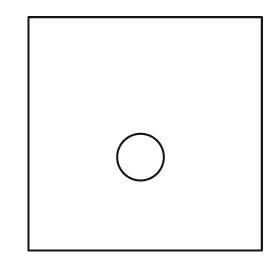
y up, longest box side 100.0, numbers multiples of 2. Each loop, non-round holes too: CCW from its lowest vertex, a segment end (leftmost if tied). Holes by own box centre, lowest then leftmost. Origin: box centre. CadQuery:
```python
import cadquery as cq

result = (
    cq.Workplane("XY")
    .moveTo(-50.0, -50.0)
    .lineTo(50.0, -50.0)
    .lineTo(50.0, 50.0)
    .lineTo(-50.0, 50.0)
    .close()
    .moveTo(-2.0, -10.0)
    .circle(10.0)
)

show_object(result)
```